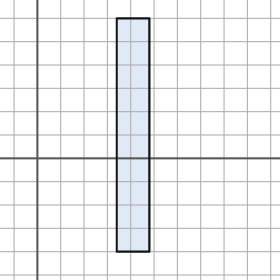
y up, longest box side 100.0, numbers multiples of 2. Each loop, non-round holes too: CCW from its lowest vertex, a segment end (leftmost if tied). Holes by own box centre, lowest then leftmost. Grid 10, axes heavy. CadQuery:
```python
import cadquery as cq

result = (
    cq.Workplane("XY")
    .moveTo(34.0, -40.0)
    .lineTo(48.0, -40.0)
    .lineTo(48.0, 60.0)
    .lineTo(34.0, 60.0)
    .close()
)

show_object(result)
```